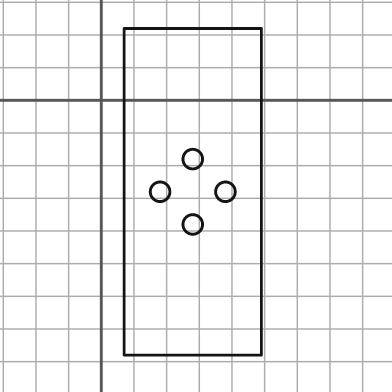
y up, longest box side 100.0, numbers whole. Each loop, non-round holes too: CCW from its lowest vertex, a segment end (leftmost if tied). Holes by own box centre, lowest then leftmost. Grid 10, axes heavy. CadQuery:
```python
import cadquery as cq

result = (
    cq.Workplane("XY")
    .moveTo(7.0, -78.0)
    .lineTo(49.0, -78.0)
    .lineTo(49.0, 22.0)
    .lineTo(7.0, 22.0)
    .close()
    .moveTo(28.0, -38.0)
    .circle(3.0)
    .moveTo(18.0, -28.0)
    .circle(3.0)
    .moveTo(38.0, -28.0)
    .circle(3.0)
    .moveTo(28.0, -18.0)
    .circle(3.0)
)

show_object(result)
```